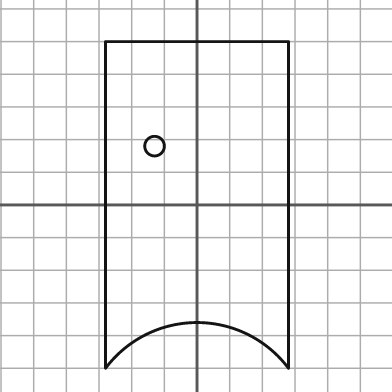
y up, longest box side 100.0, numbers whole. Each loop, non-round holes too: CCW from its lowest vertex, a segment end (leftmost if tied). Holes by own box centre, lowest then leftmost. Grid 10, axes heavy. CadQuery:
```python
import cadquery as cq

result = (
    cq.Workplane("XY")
    .moveTo(-28.0, -50.0)
    .threePointArc((0.0, -36.0), (28.0, -50.0))
    .lineTo(28.0, 50.0)
    .lineTo(-28.0, 50.0)
    .close()
    .moveTo(-13.0, 18.0)
    .circle(3.0)
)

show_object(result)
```